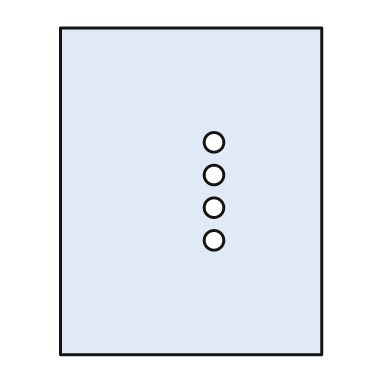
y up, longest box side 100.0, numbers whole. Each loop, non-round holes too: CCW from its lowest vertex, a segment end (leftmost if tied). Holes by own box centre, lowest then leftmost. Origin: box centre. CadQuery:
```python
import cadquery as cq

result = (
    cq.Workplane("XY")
    .moveTo(-40.0, -50.0)
    .lineTo(40.0, -50.0)
    .lineTo(40.0, 50.0)
    .lineTo(-40.0, 50.0)
    .close()
    .moveTo(7.0, -15.0)
    .circle(3.0)
    .moveTo(7.0, -5.0)
    .circle(3.0)
    .moveTo(7.0, 5.0)
    .circle(3.0)
    .moveTo(7.0, 15.0)
    .circle(3.0)
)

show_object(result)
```